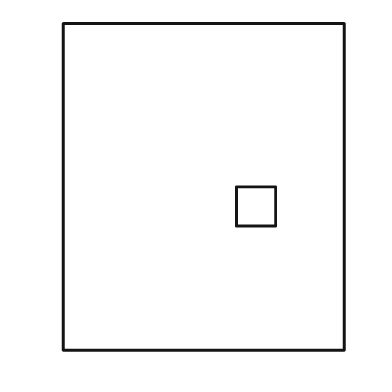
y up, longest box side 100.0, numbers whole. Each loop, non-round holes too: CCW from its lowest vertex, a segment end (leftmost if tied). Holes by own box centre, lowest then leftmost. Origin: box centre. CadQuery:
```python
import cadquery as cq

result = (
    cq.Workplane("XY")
    .moveTo(-43.0, -50.0)
    .lineTo(43.0, -50.0)
    .lineTo(43.0, 50.0)
    .lineTo(-43.0, 50.0)
    .close()
    .moveTo(10.0, -12.0)
    .lineTo(22.0, -12.0)
    .lineTo(22.0, 0.0)
    .lineTo(10.0, 0.0)
    .close()
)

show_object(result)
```